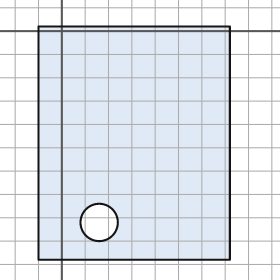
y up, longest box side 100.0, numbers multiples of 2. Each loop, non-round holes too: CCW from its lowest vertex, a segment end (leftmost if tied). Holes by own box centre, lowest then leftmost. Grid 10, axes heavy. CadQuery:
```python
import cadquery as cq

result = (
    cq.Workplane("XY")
    .moveTo(-10.0, -98.0)
    .lineTo(72.0, -98.0)
    .lineTo(72.0, 2.0)
    .lineTo(-10.0, 2.0)
    .close()
    .moveTo(16.0, -82.0)
    .circle(8.0)
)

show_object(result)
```